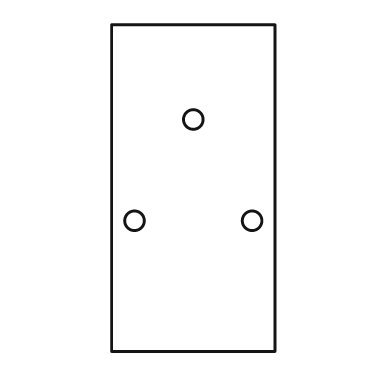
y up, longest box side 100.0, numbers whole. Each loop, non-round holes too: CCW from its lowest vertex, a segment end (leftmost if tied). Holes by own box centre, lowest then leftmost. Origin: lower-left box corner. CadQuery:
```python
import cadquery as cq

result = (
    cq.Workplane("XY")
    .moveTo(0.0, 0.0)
    .lineTo(50.0, 0.0)
    .lineTo(50.0, 100.0)
    .lineTo(0.0, 100.0)
    .close()
    .moveTo(7.0, 40.0)
    .circle(3.0)
    .moveTo(43.0, 40.0)
    .circle(3.0)
    .moveTo(25.0, 71.0)
    .circle(3.0)
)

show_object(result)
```